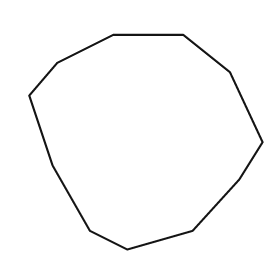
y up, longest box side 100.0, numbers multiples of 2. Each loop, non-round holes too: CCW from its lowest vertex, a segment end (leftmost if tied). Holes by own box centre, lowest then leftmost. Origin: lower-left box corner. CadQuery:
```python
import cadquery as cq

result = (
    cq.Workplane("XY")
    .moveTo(42.0, 0.0)
    .lineTo(70.0, 8.0)
    .lineTo(90.0, 30.0)
    .lineTo(100.0, 46.0)
    .lineTo(86.0, 76.0)
    .lineTo(66.0, 92.0)
    .lineTo(36.0, 92.0)
    .lineTo(12.0, 80.0)
    .lineTo(0.0, 66.0)
    .lineTo(10.0, 36.0)
    .lineTo(26.0, 8.0)
    .close()
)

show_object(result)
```